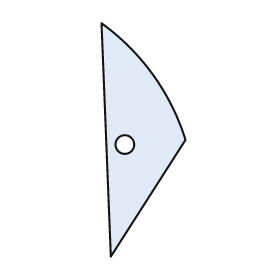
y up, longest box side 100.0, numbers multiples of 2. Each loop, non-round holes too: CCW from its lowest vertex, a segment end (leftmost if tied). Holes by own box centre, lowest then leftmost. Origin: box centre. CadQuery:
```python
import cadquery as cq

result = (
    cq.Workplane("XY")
    .moveTo(-14.0, -50.0)
    .lineTo(18.0, 0.0)
    .threePointArc((4.0, 28.0), (-18.0, 50.0))
    .close()
    .moveTo(-8.0, -2.0)
    .circle(4.0)
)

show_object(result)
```